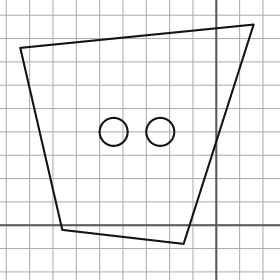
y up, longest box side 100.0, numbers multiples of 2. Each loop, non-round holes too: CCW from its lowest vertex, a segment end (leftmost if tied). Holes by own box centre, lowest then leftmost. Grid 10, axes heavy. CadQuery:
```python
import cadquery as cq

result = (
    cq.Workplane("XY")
    .moveTo(-14.0, -8.0)
    .lineTo(16.0, 86.0)
    .lineTo(-84.0, 76.0)
    .lineTo(-66.0, -2.0)
    .close()
    .moveTo(-44.0, 40.0)
    .circle(6.0)
    .moveTo(-24.0, 40.0)
    .circle(6.0)
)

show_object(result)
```